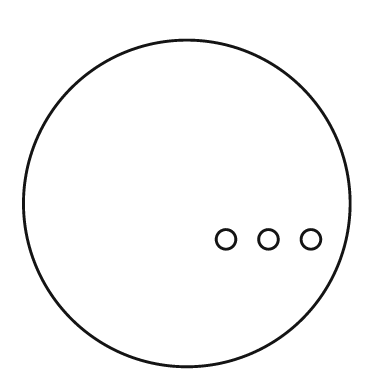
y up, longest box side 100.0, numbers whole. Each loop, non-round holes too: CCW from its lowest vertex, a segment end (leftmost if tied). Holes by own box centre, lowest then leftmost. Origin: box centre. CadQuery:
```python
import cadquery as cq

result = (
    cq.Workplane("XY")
    .moveTo(0.0, 0.0)
    .circle(50.0)
    .moveTo(12.0, -11.0)
    .circle(3.0)
    .moveTo(25.0, -11.0)
    .circle(3.0)
    .moveTo(38.0, -11.0)
    .circle(3.0)
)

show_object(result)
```